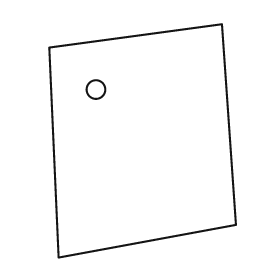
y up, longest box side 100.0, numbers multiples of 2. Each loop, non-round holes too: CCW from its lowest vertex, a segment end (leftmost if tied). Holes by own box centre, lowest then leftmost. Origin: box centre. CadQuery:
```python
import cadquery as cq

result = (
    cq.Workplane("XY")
    .moveTo(-36.0, -50.0)
    .lineTo(40.0, -36.0)
    .lineTo(34.0, 50.0)
    .lineTo(-40.0, 40.0)
    .close()
    .moveTo(-20.0, 22.0)
    .circle(4.0)
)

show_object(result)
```